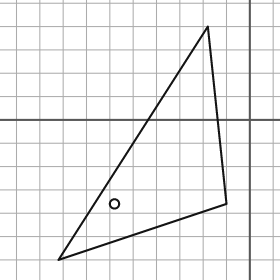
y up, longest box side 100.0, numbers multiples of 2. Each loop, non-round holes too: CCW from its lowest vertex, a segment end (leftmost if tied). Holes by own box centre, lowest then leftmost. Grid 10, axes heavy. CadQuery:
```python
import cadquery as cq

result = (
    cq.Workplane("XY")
    .moveTo(-82.0, -60.0)
    .lineTo(-10.0, -36.0)
    .lineTo(-18.0, 40.0)
    .close()
    .moveTo(-58.0, -36.0)
    .circle(2.0)
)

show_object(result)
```